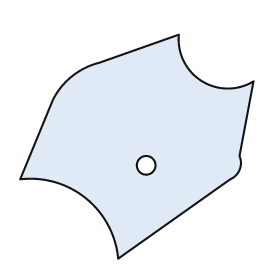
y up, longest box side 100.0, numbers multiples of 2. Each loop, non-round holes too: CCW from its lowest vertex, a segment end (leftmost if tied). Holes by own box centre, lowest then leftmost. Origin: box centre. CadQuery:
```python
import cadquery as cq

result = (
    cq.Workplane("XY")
    .moveTo(-8.0, -48.0)
    .lineTo(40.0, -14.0)
    .threePointArc((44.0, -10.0), (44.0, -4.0))
    .lineTo(50.0, 28.0)
    .threePointArc((28.0, 28.0), (18.0, 48.0))
    .lineTo(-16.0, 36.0)
    .threePointArc((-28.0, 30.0), (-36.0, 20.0))
    .lineTo(-50.0, -14.0)
    .threePointArc((-22.0, -22.0), (-8.0, -48.0))
    .close()
    .moveTo(4.0, -8.0)
    .circle(4.0)
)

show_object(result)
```